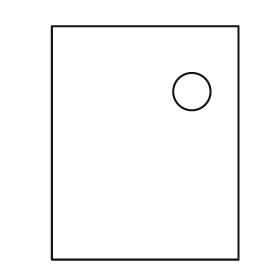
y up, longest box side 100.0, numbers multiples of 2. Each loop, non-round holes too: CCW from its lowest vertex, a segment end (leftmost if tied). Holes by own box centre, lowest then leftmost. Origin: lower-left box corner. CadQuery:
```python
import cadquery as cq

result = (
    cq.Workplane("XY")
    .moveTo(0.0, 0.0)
    .lineTo(80.0, 0.0)
    .lineTo(80.0, 100.0)
    .lineTo(0.0, 100.0)
    .close()
    .moveTo(60.0, 72.0)
    .circle(8.0)
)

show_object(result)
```